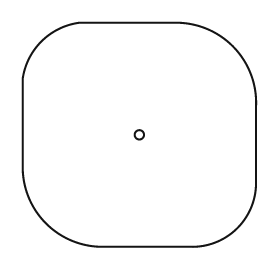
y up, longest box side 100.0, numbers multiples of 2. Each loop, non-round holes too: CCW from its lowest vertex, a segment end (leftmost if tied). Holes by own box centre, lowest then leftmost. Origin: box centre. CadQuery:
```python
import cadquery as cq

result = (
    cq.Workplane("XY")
    .moveTo(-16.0, -48.0)
    .lineTo(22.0, -48.0)
    .threePointArc((42.0, -40.0), (50.0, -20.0))
    .lineTo(50.0, 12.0)
    .threePointArc((40.0, 38.0), (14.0, 48.0))
    .lineTo(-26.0, 48.0)
    .threePointArc((-42.0, 40.0), (-50.0, 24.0))
    .lineTo(-50.0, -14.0)
    .threePointArc((-40.0, -38.0), (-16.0, -48.0))
    .close()
    .moveTo(0.0, 0.0)
    .circle(2.0)
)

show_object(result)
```